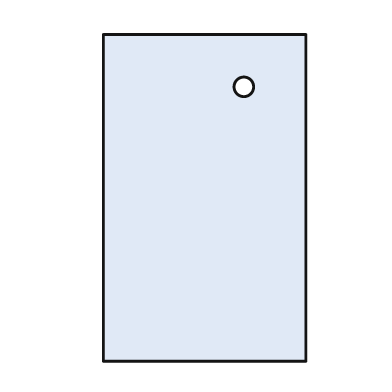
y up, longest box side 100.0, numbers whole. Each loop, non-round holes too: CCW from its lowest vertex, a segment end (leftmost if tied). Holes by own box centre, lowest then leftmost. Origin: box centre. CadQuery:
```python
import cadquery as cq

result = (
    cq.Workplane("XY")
    .moveTo(-31.0, -50.0)
    .lineTo(31.0, -50.0)
    .lineTo(31.0, 50.0)
    .lineTo(-31.0, 50.0)
    .close()
    .moveTo(12.0, 34.0)
    .circle(3.0)
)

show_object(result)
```